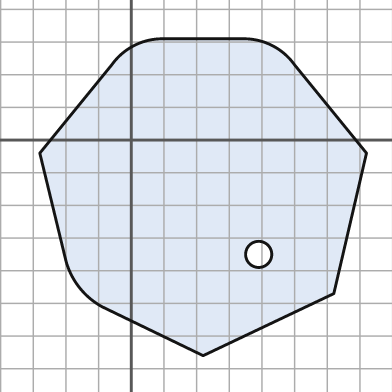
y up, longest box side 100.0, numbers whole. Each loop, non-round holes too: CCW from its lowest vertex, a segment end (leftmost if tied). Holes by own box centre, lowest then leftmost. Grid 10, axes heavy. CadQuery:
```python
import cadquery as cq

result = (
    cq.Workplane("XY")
    .moveTo(22.0, -66.0)
    .lineTo(62.0, -47.0)
    .lineTo(72.0, -4.0)
    .lineTo(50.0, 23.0)
    .threePointArc((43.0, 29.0), (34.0, 31.0))
    .lineTo(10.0, 31.0)
    .threePointArc((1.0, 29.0), (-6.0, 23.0))
    .lineTo(-28.0, -4.0)
    .lineTo(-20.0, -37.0)
    .threePointArc((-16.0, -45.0), (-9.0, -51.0))
    .close()
    .moveTo(39.0, -35.0)
    .circle(4.0)
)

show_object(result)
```